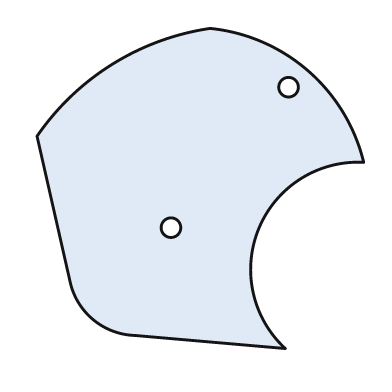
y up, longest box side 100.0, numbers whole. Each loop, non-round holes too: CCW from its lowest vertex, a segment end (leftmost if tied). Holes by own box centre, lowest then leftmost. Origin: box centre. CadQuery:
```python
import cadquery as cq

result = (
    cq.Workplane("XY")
    .moveTo(26.0, -49.0)
    .threePointArc((18.0, -12.0), (50.0, 8.0))
    .threePointArc((33.0, 36.0), (3.0, 49.0))
    .threePointArc((-27.0, 38.0), (-50.0, 16.0))
    .lineTo(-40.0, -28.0)
    .threePointArc((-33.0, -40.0), (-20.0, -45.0))
    .close()
    .moveTo(-9.0, -12.0)
    .circle(3.0)
    .moveTo(27.0, 31.0)
    .circle(3.0)
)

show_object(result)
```